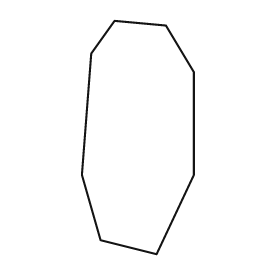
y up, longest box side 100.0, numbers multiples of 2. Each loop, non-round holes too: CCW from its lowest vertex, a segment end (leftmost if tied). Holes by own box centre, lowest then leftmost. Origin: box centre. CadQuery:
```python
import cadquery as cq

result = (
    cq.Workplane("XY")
    .moveTo(8.0, -50.0)
    .lineTo(24.0, -16.0)
    .lineTo(24.0, 28.0)
    .lineTo(12.0, 48.0)
    .lineTo(-10.0, 50.0)
    .lineTo(-20.0, 36.0)
    .lineTo(-24.0, -16.0)
    .lineTo(-16.0, -44.0)
    .close()
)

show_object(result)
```